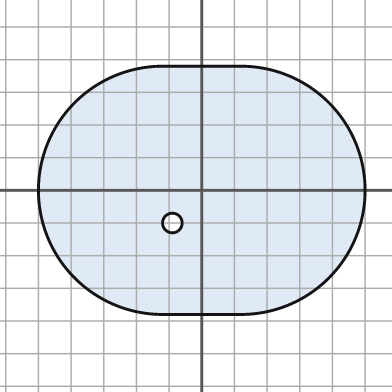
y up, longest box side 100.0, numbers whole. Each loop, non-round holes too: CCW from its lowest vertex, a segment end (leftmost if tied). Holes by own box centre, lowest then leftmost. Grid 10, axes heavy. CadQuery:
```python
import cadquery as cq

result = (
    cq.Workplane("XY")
    .moveTo(-12.0, -38.0)
    .lineTo(12.0, -38.0)
    .threePointArc((50.0, 0.0), (12.0, 38.0))
    .lineTo(-12.0, 38.0)
    .threePointArc((-50.0, 0.0), (-12.0, -38.0))
    .close()
    .moveTo(-9.0, -10.0)
    .circle(3.0)
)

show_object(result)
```